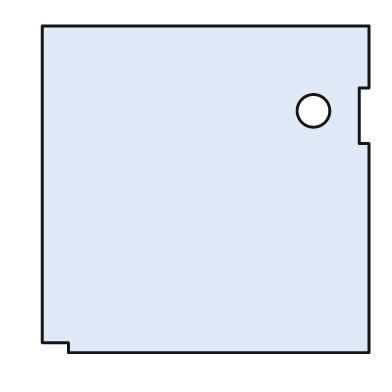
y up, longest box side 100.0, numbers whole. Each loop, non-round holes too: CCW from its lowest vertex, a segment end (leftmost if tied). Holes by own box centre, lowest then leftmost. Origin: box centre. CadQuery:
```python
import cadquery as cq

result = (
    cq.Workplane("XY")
    .moveTo(-42.0, -50.0)
    .lineTo(50.0, -50.0)
    .lineTo(50.0, 14.0)
    .lineTo(47.0, 14.0)
    .lineTo(47.0, 31.0)
    .lineTo(50.0, 31.0)
    .lineTo(50.0, 50.0)
    .lineTo(-50.0, 50.0)
    .lineTo(-50.0, -47.0)
    .lineTo(-42.0, -47.0)
    .close()
    .moveTo(33.0, 24.0)
    .circle(5.0)
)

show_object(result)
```